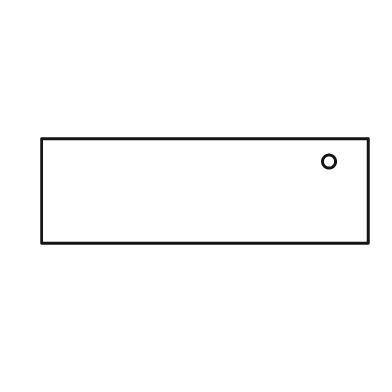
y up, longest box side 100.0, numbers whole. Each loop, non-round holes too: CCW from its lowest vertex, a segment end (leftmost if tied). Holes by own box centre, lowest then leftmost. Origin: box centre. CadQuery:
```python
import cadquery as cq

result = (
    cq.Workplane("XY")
    .moveTo(-50.0, -16.0)
    .lineTo(50.0, -16.0)
    .lineTo(50.0, 16.0)
    .lineTo(-50.0, 16.0)
    .close()
    .moveTo(38.0, 9.0)
    .circle(2.0)
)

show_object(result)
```